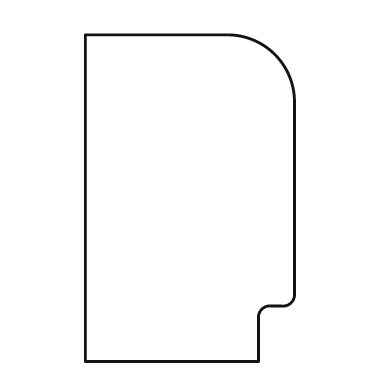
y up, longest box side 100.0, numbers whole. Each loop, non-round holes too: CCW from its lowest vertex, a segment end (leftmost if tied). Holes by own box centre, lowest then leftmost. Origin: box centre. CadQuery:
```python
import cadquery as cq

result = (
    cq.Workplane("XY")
    .moveTo(-32.0, -50.0)
    .lineTo(21.0, -50.0)
    .lineTo(21.0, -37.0)
    .threePointArc((22.0, -34.0), (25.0, -33.0))
    .lineTo(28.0, -33.0)
    .threePointArc((31.0, -32.0), (32.0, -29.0))
    .lineTo(32.0, 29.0)
    .threePointArc((26.0, 44.0), (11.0, 50.0))
    .lineTo(-32.0, 50.0)
    .close()
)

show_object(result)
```